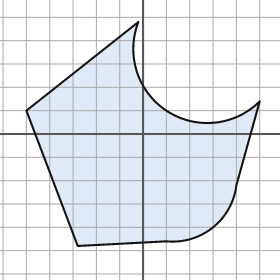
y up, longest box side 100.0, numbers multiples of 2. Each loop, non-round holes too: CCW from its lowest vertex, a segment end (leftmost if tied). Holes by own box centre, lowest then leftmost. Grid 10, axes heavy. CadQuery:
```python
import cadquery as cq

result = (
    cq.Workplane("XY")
    .moveTo(-28.0, -48.0)
    .lineTo(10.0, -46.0)
    .threePointArc((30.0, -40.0), (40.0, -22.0))
    .lineTo(50.0, 14.0)
    .threePointArc((10.0, 10.0), (-2.0, 48.0))
    .lineTo(-50.0, 10.0)
    .close()
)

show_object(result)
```